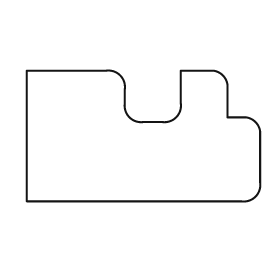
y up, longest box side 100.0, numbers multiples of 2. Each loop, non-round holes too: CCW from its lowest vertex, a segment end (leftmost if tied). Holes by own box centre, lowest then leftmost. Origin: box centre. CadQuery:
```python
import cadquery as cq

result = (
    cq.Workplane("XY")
    .moveTo(-50.0, -28.0)
    .lineTo(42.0, -28.0)
    .threePointArc((48.0, -26.0), (50.0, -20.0))
    .lineTo(50.0, 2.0)
    .threePointArc((48.0, 6.0), (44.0, 8.0))
    .lineTo(36.0, 8.0)
    .lineTo(36.0, 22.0)
    .threePointArc((34.0, 26.0), (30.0, 28.0))
    .lineTo(16.0, 28.0)
    .lineTo(16.0, 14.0)
    .threePointArc((14.0, 8.0), (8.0, 6.0))
    .lineTo(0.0, 6.0)
    .threePointArc((-6.0, 8.0), (-8.0, 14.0))
    .lineTo(-8.0, 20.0)
    .threePointArc((-10.0, 26.0), (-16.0, 28.0))
    .lineTo(-50.0, 28.0)
    .close()
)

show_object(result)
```